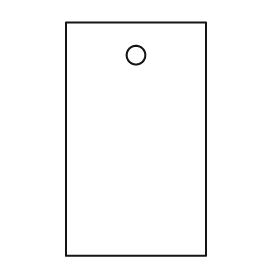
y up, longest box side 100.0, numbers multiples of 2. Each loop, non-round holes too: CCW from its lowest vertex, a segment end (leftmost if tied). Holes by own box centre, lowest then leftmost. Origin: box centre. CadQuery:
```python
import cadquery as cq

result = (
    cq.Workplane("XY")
    .moveTo(-30.0, -50.0)
    .lineTo(30.0, -50.0)
    .lineTo(30.0, 50.0)
    .lineTo(-30.0, 50.0)
    .close()
    .moveTo(0.0, 36.0)
    .circle(4.0)
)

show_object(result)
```